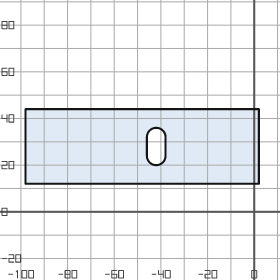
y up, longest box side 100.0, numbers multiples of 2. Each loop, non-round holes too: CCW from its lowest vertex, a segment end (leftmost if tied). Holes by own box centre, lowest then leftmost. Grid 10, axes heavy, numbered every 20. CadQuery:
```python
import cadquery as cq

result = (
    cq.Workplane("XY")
    .moveTo(-98.0, 12.0)
    .lineTo(2.0, 12.0)
    .lineTo(2.0, 44.0)
    .lineTo(-98.0, 44.0)
    .close()
    .moveTo(-46.0, 24.0)
    .threePointArc((-42.0, 20.0), (-38.0, 24.0))
    .lineTo(-38.0, 32.0)
    .threePointArc((-42.0, 36.0), (-46.0, 32.0))
    .close()
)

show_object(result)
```